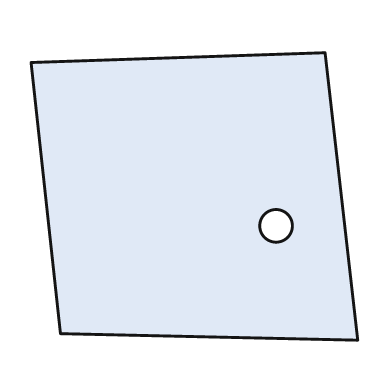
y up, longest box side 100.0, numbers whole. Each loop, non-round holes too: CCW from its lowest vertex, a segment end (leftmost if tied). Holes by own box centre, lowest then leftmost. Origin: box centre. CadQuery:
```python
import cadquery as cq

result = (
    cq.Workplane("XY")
    .moveTo(50.0, -44.0)
    .lineTo(40.0, 44.0)
    .lineTo(-50.0, 41.0)
    .lineTo(-41.0, -42.0)
    .close()
    .moveTo(25.0, -9.0)
    .circle(5.0)
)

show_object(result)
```